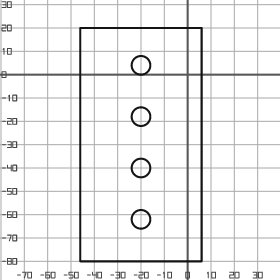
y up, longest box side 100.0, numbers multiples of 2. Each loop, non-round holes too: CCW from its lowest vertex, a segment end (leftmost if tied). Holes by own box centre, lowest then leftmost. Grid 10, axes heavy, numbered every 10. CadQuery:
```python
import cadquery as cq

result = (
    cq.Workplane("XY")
    .moveTo(-46.0, -80.0)
    .lineTo(6.0, -80.0)
    .lineTo(6.0, 20.0)
    .lineTo(-46.0, 20.0)
    .close()
    .moveTo(-20.0, -62.0)
    .circle(4.0)
    .moveTo(-20.0, -40.0)
    .circle(4.0)
    .moveTo(-20.0, -18.0)
    .circle(4.0)
    .moveTo(-20.0, 4.0)
    .circle(4.0)
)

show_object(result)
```